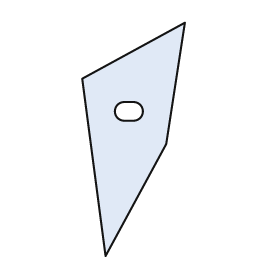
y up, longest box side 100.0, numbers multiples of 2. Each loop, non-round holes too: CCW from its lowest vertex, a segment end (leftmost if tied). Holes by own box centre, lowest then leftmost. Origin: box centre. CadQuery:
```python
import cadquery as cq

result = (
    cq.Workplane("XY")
    .moveTo(-12.0, -50.0)
    .lineTo(14.0, -2.0)
    .lineTo(22.0, 50.0)
    .lineTo(-22.0, 26.0)
    .close()
    .moveTo(-4.0, 8.0)
    .lineTo(0.0, 8.0)
    .threePointArc((4.0, 12.0), (0.0, 16.0))
    .lineTo(-4.0, 16.0)
    .threePointArc((-8.0, 12.0), (-4.0, 8.0))
    .close()
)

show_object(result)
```